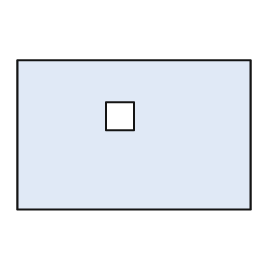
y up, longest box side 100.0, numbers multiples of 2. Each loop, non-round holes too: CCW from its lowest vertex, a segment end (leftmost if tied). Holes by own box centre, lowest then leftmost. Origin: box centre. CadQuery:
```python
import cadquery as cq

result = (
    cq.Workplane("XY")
    .moveTo(-50.0, -32.0)
    .lineTo(50.0, -32.0)
    .lineTo(50.0, 32.0)
    .lineTo(-50.0, 32.0)
    .close()
    .moveTo(-12.0, 2.0)
    .lineTo(0.0, 2.0)
    .lineTo(0.0, 14.0)
    .lineTo(-12.0, 14.0)
    .close()
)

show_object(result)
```